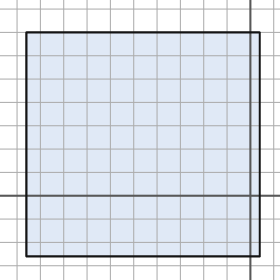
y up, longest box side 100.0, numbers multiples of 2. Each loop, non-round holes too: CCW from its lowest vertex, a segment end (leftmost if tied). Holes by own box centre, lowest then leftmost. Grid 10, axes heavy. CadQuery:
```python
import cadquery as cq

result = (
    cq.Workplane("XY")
    .moveTo(-96.0, -26.0)
    .lineTo(4.0, -26.0)
    .lineTo(4.0, 70.0)
    .lineTo(-96.0, 70.0)
    .close()
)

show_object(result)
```